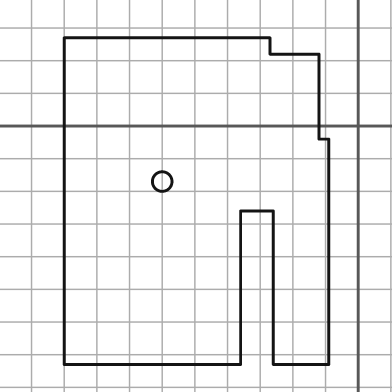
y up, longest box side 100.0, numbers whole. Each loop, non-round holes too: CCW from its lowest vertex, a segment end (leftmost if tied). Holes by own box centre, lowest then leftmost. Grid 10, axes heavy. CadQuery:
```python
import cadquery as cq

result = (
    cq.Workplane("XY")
    .moveTo(-90.0, -73.0)
    .lineTo(-36.0, -73.0)
    .lineTo(-36.0, -26.0)
    .lineTo(-26.0, -26.0)
    .lineTo(-26.0, -73.0)
    .lineTo(-9.0, -73.0)
    .lineTo(-9.0, -4.0)
    .lineTo(-12.0, -4.0)
    .lineTo(-12.0, 22.0)
    .lineTo(-27.0, 22.0)
    .lineTo(-27.0, 27.0)
    .lineTo(-90.0, 27.0)
    .close()
    .moveTo(-60.0, -17.0)
    .circle(3.0)
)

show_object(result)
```